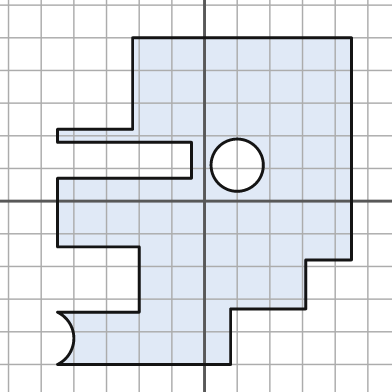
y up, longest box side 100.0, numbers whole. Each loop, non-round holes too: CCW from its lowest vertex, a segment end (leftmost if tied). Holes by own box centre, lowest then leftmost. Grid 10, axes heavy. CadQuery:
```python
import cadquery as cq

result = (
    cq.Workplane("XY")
    .moveTo(-45.0, -50.0)
    .lineTo(8.0, -50.0)
    .lineTo(8.0, -33.0)
    .lineTo(31.0, -33.0)
    .lineTo(31.0, -18.0)
    .lineTo(45.0, -18.0)
    .lineTo(45.0, 50.0)
    .lineTo(-22.0, 50.0)
    .lineTo(-22.0, 22.0)
    .lineTo(-45.0, 22.0)
    .lineTo(-45.0, 18.0)
    .lineTo(-4.0, 18.0)
    .lineTo(-4.0, 7.0)
    .lineTo(-45.0, 7.0)
    .lineTo(-45.0, -14.0)
    .lineTo(-20.0, -14.0)
    .lineTo(-20.0, -34.0)
    .lineTo(-45.0, -34.0)
    .threePointArc((-40.0, -42.0), (-45.0, -50.0))
    .close()
    .moveTo(10.0, 11.0)
    .circle(8.0)
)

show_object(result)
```